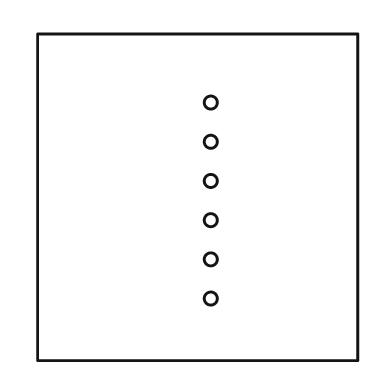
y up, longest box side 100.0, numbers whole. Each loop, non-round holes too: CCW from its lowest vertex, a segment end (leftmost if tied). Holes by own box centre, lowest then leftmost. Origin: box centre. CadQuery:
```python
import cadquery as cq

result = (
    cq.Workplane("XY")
    .moveTo(-49.0, -50.0)
    .lineTo(49.0, -50.0)
    .lineTo(49.0, 50.0)
    .lineTo(-49.0, 50.0)
    .close()
    .moveTo(4.0, -31.0)
    .circle(2.0)
    .moveTo(4.0, -19.0)
    .circle(2.0)
    .moveTo(4.0, -7.0)
    .circle(2.0)
    .moveTo(4.0, 5.0)
    .circle(2.0)
    .moveTo(4.0, 17.0)
    .circle(2.0)
    .moveTo(4.0, 29.0)
    .circle(2.0)
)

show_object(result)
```